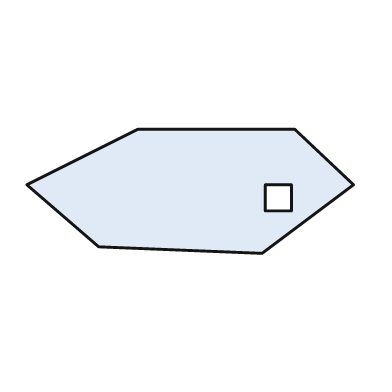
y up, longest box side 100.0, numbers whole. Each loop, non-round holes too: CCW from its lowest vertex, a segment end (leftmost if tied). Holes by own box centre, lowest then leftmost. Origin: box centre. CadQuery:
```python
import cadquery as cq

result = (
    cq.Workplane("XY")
    .moveTo(22.0, -19.0)
    .lineTo(50.0, 2.0)
    .lineTo(32.0, 19.0)
    .lineTo(-16.0, 19.0)
    .lineTo(-50.0, 2.0)
    .lineTo(-28.0, -17.0)
    .close()
    .moveTo(23.0, -6.0)
    .lineTo(31.0, -6.0)
    .lineTo(31.0, 2.0)
    .lineTo(23.0, 2.0)
    .close()
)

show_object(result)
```